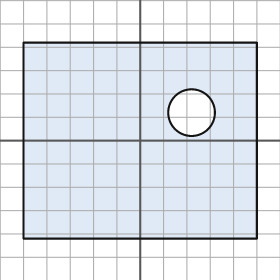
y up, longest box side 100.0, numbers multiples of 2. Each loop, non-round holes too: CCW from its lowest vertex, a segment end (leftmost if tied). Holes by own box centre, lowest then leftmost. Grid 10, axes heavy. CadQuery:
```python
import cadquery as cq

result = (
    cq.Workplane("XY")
    .moveTo(-50.0, -42.0)
    .lineTo(50.0, -42.0)
    .lineTo(50.0, 42.0)
    .lineTo(-50.0, 42.0)
    .close()
    .moveTo(22.0, 12.0)
    .circle(10.0)
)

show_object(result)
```